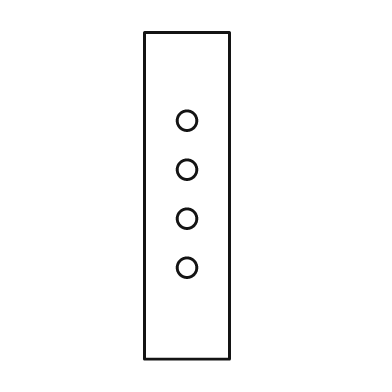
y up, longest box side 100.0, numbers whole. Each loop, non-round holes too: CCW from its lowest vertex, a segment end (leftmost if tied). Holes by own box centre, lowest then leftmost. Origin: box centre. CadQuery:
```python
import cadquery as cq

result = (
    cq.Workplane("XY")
    .moveTo(-13.0, -50.0)
    .lineTo(13.0, -50.0)
    .lineTo(13.0, 50.0)
    .lineTo(-13.0, 50.0)
    .close()
    .moveTo(0.0, -22.0)
    .circle(3.0)
    .moveTo(0.0, -7.0)
    .circle(3.0)
    .moveTo(0.0, 8.0)
    .circle(3.0)
    .moveTo(0.0, 23.0)
    .circle(3.0)
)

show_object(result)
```